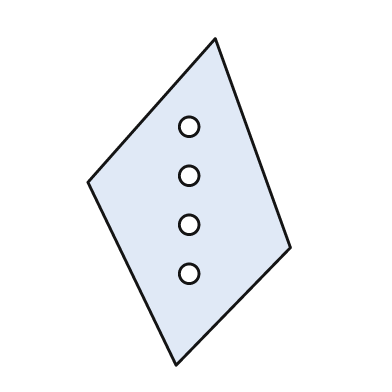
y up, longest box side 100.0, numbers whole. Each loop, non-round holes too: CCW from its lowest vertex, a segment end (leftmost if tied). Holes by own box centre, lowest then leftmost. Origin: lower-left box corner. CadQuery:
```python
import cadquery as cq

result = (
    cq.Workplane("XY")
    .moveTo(27.0, 0.0)
    .lineTo(62.0, 36.0)
    .lineTo(39.0, 100.0)
    .lineTo(0.0, 56.0)
    .close()
    .moveTo(31.0, 28.0)
    .circle(3.0)
    .moveTo(31.0, 43.0)
    .circle(3.0)
    .moveTo(31.0, 58.0)
    .circle(3.0)
    .moveTo(31.0, 73.0)
    .circle(3.0)
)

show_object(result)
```